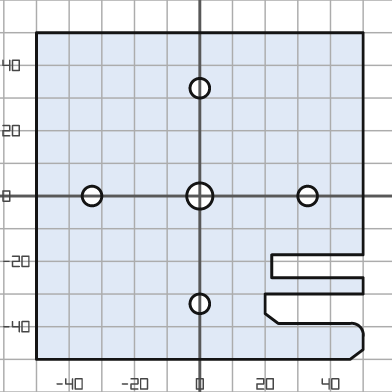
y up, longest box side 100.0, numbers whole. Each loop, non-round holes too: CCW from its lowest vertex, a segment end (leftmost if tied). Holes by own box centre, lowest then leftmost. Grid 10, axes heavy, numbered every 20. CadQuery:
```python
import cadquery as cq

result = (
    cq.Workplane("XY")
    .moveTo(-50.0, -50.0)
    .lineTo(46.0, -50.0)
    .lineTo(50.0, -47.0)
    .lineTo(50.0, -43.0)
    .threePointArc((49.0, -40.0), (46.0, -39.0))
    .lineTo(24.0, -39.0)
    .lineTo(20.0, -36.0)
    .lineTo(20.0, -30.0)
    .lineTo(50.0, -30.0)
    .lineTo(50.0, -25.0)
    .lineTo(22.0, -25.0)
    .lineTo(22.0, -18.0)
    .lineTo(50.0, -18.0)
    .lineTo(50.0, 50.0)
    .lineTo(-50.0, 50.0)
    .close()
    .moveTo(0.0, -33.0)
    .circle(3.0)
    .moveTo(-33.0, 0.0)
    .circle(3.0)
    .moveTo(0.0, 0.0)
    .circle(4.0)
    .moveTo(33.0, 0.0)
    .circle(3.0)
    .moveTo(0.0, 33.0)
    .circle(3.0)
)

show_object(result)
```